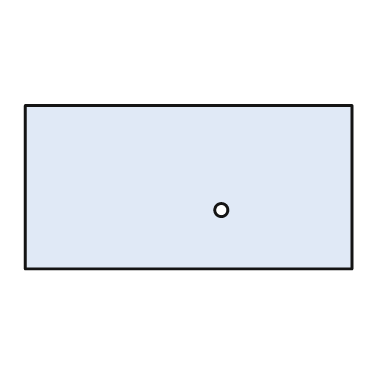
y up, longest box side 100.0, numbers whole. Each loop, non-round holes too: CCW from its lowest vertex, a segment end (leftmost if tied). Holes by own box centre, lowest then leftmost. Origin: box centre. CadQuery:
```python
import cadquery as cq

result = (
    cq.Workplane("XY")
    .moveTo(-50.0, -25.0)
    .lineTo(50.0, -25.0)
    .lineTo(50.0, 25.0)
    .lineTo(-50.0, 25.0)
    .close()
    .moveTo(10.0, -7.0)
    .circle(2.0)
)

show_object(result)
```